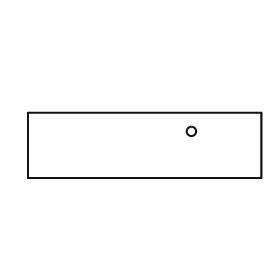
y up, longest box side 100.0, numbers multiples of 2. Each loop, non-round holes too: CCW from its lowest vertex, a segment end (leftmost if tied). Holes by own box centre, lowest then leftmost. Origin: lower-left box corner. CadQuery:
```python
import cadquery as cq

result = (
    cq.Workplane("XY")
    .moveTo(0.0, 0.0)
    .lineTo(100.0, 0.0)
    .lineTo(100.0, 28.0)
    .lineTo(0.0, 28.0)
    .close()
    .moveTo(70.0, 20.0)
    .circle(2.0)
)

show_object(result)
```